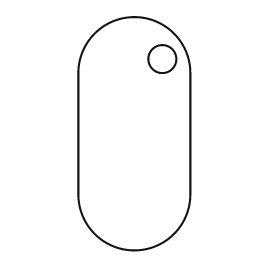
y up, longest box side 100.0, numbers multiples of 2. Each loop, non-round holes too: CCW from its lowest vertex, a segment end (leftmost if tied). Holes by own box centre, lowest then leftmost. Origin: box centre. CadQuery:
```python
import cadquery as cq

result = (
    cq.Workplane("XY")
    .moveTo(-24.0, -26.0)
    .threePointArc((0.0, -50.0), (24.0, -26.0))
    .lineTo(24.0, 26.0)
    .threePointArc((0.0, 50.0), (-24.0, 26.0))
    .close()
    .moveTo(12.0, 32.0)
    .circle(6.0)
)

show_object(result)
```